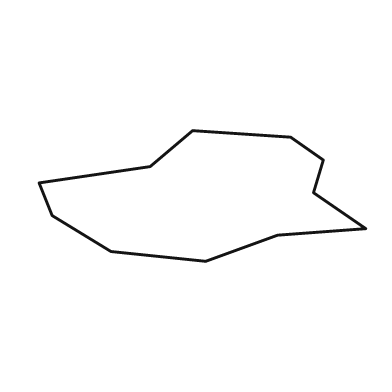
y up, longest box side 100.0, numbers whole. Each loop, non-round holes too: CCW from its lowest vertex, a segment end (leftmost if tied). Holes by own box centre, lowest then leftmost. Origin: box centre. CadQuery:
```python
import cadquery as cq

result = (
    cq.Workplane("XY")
    .moveTo(1.0, -20.0)
    .lineTo(23.0, -12.0)
    .lineTo(50.0, -10.0)
    .lineTo(34.0, 1.0)
    .lineTo(37.0, 11.0)
    .lineTo(27.0, 18.0)
    .lineTo(-3.0, 20.0)
    .lineTo(-16.0, 9.0)
    .lineTo(-50.0, 4.0)
    .lineTo(-46.0, -6.0)
    .lineTo(-28.0, -17.0)
    .close()
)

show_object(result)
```